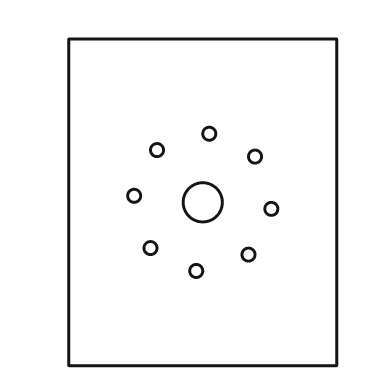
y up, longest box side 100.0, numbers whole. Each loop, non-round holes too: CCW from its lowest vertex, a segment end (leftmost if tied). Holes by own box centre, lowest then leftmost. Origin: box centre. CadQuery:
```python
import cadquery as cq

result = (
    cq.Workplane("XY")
    .moveTo(-41.0, -50.0)
    .lineTo(41.0, -50.0)
    .lineTo(41.0, 50.0)
    .lineTo(-41.0, 50.0)
    .close()
    .moveTo(-2.0, -21.0)
    .circle(2.0)
    .moveTo(14.0, -16.0)
    .circle(2.0)
    .moveTo(-16.0, -14.0)
    .circle(2.0)
    .moveTo(21.0, -2.0)
    .circle(2.0)
    .moveTo(0.0, 0.0)
    .circle(6.0)
    .moveTo(-21.0, 2.0)
    .circle(2.0)
    .moveTo(16.0, 14.0)
    .circle(2.0)
    .moveTo(-14.0, 16.0)
    .circle(2.0)
    .moveTo(2.0, 21.0)
    .circle(2.0)
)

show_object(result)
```